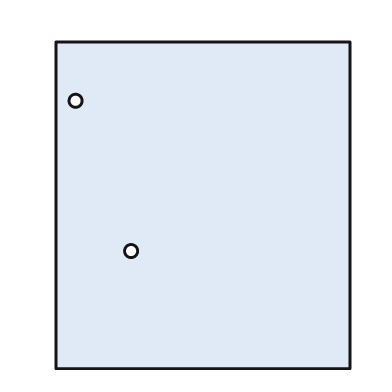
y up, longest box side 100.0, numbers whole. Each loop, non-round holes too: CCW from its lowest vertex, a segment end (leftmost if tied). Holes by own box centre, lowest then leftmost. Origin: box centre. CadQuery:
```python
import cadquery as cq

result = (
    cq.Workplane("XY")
    .moveTo(-45.0, -50.0)
    .lineTo(45.0, -50.0)
    .lineTo(45.0, 50.0)
    .lineTo(-45.0, 50.0)
    .close()
    .moveTo(-22.0, -14.0)
    .circle(2.0)
    .moveTo(-39.0, 32.0)
    .circle(2.0)
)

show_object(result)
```